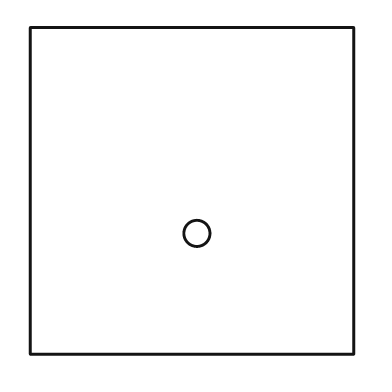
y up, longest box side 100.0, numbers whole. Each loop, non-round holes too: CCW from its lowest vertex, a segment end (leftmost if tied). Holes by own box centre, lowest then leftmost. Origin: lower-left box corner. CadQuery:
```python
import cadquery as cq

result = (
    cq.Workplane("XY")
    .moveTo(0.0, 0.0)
    .lineTo(99.0, 0.0)
    .lineTo(99.0, 100.0)
    .lineTo(0.0, 100.0)
    .close()
    .moveTo(51.0, 37.0)
    .circle(4.0)
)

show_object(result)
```